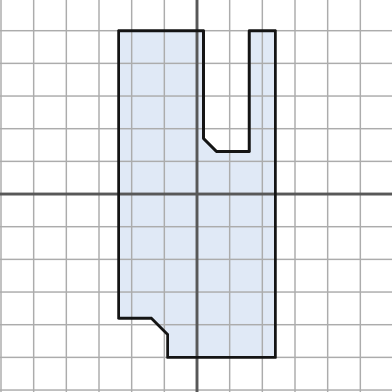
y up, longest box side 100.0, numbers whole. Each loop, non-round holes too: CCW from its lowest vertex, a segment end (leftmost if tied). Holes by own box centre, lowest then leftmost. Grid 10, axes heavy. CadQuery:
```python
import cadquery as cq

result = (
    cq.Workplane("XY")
    .moveTo(-9.0, -50.0)
    .lineTo(24.0, -50.0)
    .lineTo(24.0, 50.0)
    .lineTo(16.0, 50.0)
    .lineTo(16.0, 13.0)
    .lineTo(6.0, 13.0)
    .lineTo(2.0, 17.0)
    .lineTo(2.0, 50.0)
    .lineTo(-24.0, 50.0)
    .lineTo(-24.0, -38.0)
    .lineTo(-14.0, -38.0)
    .lineTo(-9.0, -43.0)
    .close()
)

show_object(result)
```